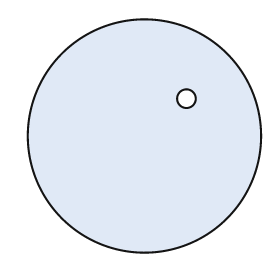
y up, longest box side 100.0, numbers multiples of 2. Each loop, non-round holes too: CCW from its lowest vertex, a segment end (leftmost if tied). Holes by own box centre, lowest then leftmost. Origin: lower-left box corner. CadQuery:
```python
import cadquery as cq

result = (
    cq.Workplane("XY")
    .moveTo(50.0, 50.0)
    .circle(50.0)
    .moveTo(68.0, 66.0)
    .circle(4.0)
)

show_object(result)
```